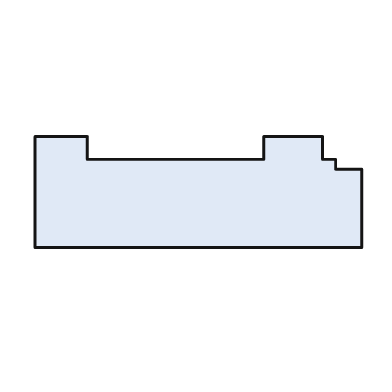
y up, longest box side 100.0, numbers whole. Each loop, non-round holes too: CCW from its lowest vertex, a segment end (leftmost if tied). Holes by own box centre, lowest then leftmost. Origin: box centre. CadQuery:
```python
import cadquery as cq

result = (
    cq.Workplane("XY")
    .moveTo(-50.0, -17.0)
    .lineTo(50.0, -17.0)
    .lineTo(50.0, 7.0)
    .lineTo(42.0, 7.0)
    .lineTo(42.0, 10.0)
    .lineTo(38.0, 10.0)
    .lineTo(38.0, 17.0)
    .lineTo(20.0, 17.0)
    .lineTo(20.0, 10.0)
    .lineTo(-34.0, 10.0)
    .lineTo(-34.0, 17.0)
    .lineTo(-50.0, 17.0)
    .close()
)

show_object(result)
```